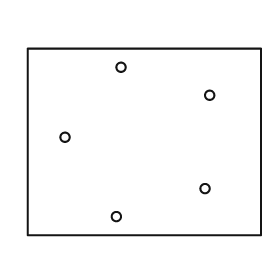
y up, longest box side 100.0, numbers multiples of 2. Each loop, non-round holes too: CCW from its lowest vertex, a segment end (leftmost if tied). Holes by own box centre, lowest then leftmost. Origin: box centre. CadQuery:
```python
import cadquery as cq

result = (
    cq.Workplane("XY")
    .moveTo(-50.0, -40.0)
    .lineTo(50.0, -40.0)
    .lineTo(50.0, 40.0)
    .lineTo(-50.0, 40.0)
    .close()
    .moveTo(-12.0, -32.0)
    .circle(2.0)
    .moveTo(26.0, -20.0)
    .circle(2.0)
    .moveTo(-34.0, 2.0)
    .circle(2.0)
    .moveTo(28.0, 20.0)
    .circle(2.0)
    .moveTo(-10.0, 32.0)
    .circle(2.0)
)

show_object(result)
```